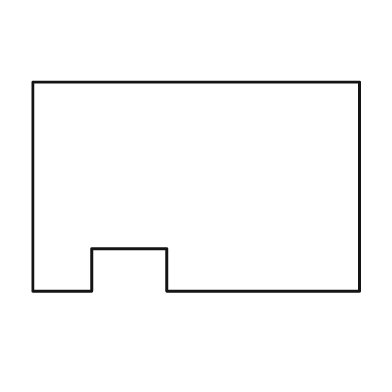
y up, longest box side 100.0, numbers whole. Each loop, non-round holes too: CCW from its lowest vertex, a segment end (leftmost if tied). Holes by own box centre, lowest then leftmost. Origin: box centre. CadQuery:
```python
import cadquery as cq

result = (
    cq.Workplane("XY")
    .moveTo(-50.0, -32.0)
    .lineTo(-32.0, -32.0)
    .lineTo(-32.0, -19.0)
    .lineTo(-9.0, -19.0)
    .lineTo(-9.0, -32.0)
    .lineTo(50.0, -32.0)
    .lineTo(50.0, 32.0)
    .lineTo(-50.0, 32.0)
    .close()
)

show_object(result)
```